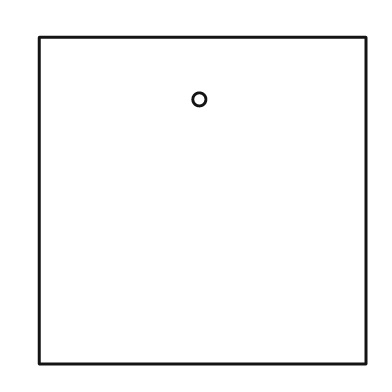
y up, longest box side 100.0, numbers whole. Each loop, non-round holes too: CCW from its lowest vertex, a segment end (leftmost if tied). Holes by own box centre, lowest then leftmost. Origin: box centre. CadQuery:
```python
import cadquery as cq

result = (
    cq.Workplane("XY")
    .moveTo(-50.0, -50.0)
    .lineTo(50.0, -50.0)
    .lineTo(50.0, 50.0)
    .lineTo(-50.0, 50.0)
    .close()
    .moveTo(-1.0, 31.0)
    .circle(2.0)
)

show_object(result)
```